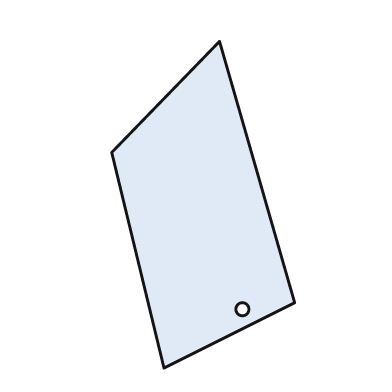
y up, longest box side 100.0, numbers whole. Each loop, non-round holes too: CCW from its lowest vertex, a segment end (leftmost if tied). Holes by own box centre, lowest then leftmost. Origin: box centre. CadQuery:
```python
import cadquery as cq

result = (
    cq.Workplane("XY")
    .moveTo(-12.0, -50.0)
    .lineTo(28.0, -30.0)
    .lineTo(5.0, 50.0)
    .lineTo(-28.0, 16.0)
    .close()
    .moveTo(12.0, -32.0)
    .circle(2.0)
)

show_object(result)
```